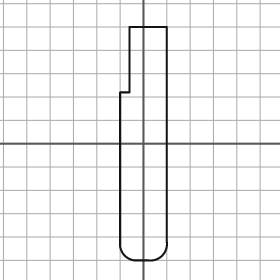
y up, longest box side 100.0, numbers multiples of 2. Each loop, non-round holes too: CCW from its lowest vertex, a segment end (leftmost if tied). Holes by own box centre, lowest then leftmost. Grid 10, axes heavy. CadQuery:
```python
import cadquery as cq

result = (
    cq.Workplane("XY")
    .moveTo(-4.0, -50.0)
    .lineTo(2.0, -50.0)
    .threePointArc((8.0, -48.0), (10.0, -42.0))
    .lineTo(10.0, 50.0)
    .lineTo(-6.0, 50.0)
    .lineTo(-6.0, 22.0)
    .lineTo(-10.0, 22.0)
    .lineTo(-10.0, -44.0)
    .threePointArc((-8.0, -48.0), (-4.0, -50.0))
    .close()
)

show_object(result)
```